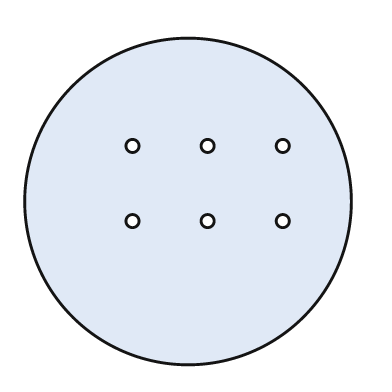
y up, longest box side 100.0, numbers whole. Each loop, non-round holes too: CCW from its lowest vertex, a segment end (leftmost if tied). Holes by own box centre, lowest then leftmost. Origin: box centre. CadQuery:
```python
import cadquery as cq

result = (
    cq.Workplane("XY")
    .moveTo(0.0, 0.0)
    .circle(50.0)
    .moveTo(-17.0, -6.0)
    .circle(2.0)
    .moveTo(6.0, -6.0)
    .circle(2.0)
    .moveTo(29.0, -6.0)
    .circle(2.0)
    .moveTo(-17.0, 17.0)
    .circle(2.0)
    .moveTo(6.0, 17.0)
    .circle(2.0)
    .moveTo(29.0, 17.0)
    .circle(2.0)
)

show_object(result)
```